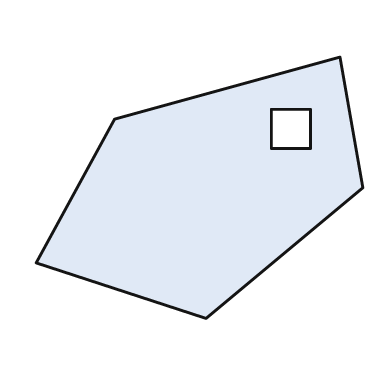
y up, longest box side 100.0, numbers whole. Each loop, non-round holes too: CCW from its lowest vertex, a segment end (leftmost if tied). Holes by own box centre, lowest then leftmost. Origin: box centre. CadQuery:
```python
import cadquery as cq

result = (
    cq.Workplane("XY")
    .moveTo(2.0, -40.0)
    .lineTo(50.0, 0.0)
    .lineTo(43.0, 40.0)
    .lineTo(-26.0, 21.0)
    .lineTo(-50.0, -23.0)
    .close()
    .moveTo(22.0, 12.0)
    .lineTo(34.0, 12.0)
    .lineTo(34.0, 24.0)
    .lineTo(22.0, 24.0)
    .close()
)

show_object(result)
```